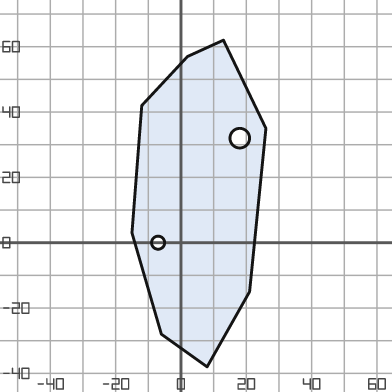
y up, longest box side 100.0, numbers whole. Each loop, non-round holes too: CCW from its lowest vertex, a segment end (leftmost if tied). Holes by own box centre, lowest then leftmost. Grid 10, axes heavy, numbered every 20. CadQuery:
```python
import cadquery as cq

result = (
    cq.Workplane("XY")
    .moveTo(8.0, -38.0)
    .lineTo(21.0, -15.0)
    .lineTo(26.0, 35.0)
    .lineTo(13.0, 62.0)
    .lineTo(2.0, 57.0)
    .lineTo(-12.0, 42.0)
    .lineTo(-15.0, 3.0)
    .lineTo(-6.0, -28.0)
    .close()
    .moveTo(-7.0, 0.0)
    .circle(2.0)
    .moveTo(18.0, 32.0)
    .circle(3.0)
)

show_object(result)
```